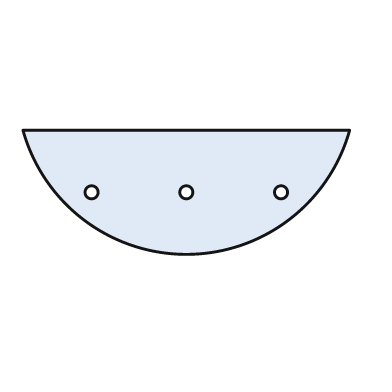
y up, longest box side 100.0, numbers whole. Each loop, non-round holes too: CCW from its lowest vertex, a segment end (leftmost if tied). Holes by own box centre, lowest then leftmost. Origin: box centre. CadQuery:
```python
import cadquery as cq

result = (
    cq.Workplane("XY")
    .moveTo(-50.0, 19.0)
    .threePointArc((0.0, -19.0), (50.0, 19.0))
    .close()
    .moveTo(-29.0, 0.0)
    .circle(2.0)
    .moveTo(0.0, 0.0)
    .circle(2.0)
    .moveTo(29.0, 0.0)
    .circle(2.0)
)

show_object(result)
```